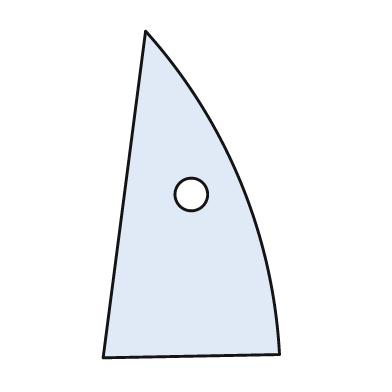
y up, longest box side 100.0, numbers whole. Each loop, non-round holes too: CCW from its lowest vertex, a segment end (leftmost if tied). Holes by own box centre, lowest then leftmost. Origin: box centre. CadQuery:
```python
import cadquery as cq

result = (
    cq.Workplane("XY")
    .moveTo(-27.0, -50.0)
    .lineTo(27.0, -49.0)
    .threePointArc((15.0, 4.0), (-14.0, 50.0))
    .close()
    .moveTo(0.0, 0.0)
    .circle(5.0)
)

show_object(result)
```